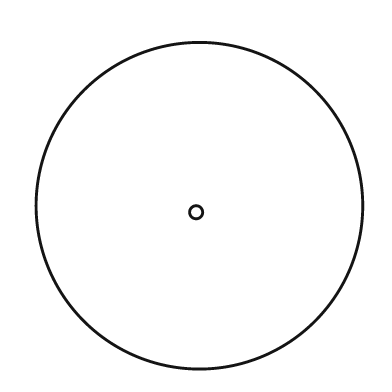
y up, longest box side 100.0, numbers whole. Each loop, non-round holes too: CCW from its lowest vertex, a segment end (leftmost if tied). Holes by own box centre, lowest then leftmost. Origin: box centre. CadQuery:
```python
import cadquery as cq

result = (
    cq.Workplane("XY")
    .moveTo(0.0, 0.0)
    .circle(50.0)
    .moveTo(-1.0, -2.0)
    .circle(2.0)
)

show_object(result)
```